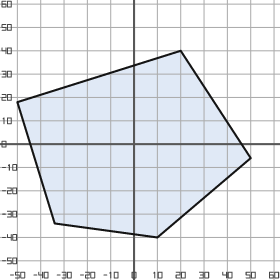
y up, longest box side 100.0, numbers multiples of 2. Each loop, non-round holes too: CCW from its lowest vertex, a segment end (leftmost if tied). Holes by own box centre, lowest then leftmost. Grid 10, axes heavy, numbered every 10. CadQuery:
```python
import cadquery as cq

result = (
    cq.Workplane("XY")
    .moveTo(10.0, -40.0)
    .lineTo(50.0, -6.0)
    .lineTo(20.0, 40.0)
    .lineTo(-50.0, 18.0)
    .lineTo(-34.0, -34.0)
    .close()
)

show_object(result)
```